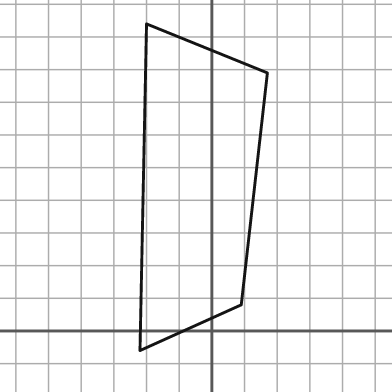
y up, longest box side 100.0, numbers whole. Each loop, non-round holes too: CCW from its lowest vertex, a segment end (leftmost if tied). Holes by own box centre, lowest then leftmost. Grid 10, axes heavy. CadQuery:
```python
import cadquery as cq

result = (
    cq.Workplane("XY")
    .moveTo(-22.0, -6.0)
    .lineTo(9.0, 8.0)
    .lineTo(17.0, 79.0)
    .lineTo(-20.0, 94.0)
    .close()
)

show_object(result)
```